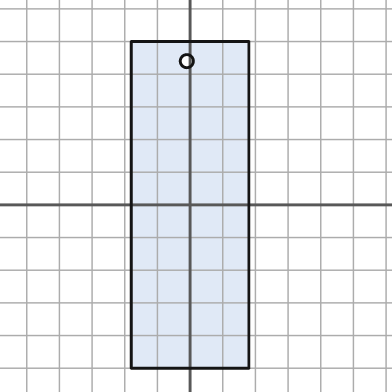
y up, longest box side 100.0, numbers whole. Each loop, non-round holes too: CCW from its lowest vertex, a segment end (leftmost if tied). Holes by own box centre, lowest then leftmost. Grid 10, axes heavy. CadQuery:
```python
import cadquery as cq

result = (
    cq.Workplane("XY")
    .moveTo(-18.0, -50.0)
    .lineTo(18.0, -50.0)
    .lineTo(18.0, 50.0)
    .lineTo(-18.0, 50.0)
    .close()
    .moveTo(-1.0, 44.0)
    .circle(2.0)
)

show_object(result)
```